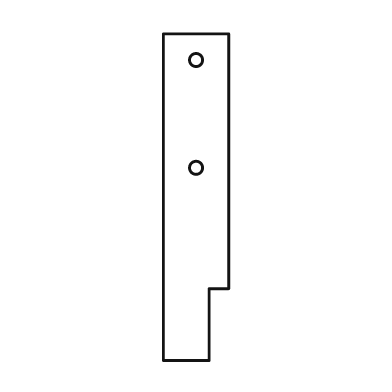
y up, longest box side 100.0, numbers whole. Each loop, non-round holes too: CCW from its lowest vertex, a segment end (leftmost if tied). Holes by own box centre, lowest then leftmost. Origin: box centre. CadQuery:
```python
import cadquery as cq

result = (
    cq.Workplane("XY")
    .moveTo(-10.0, -50.0)
    .lineTo(4.0, -50.0)
    .lineTo(4.0, -28.0)
    .lineTo(10.0, -28.0)
    .lineTo(10.0, 50.0)
    .lineTo(-10.0, 50.0)
    .close()
    .moveTo(0.0, 9.0)
    .circle(2.0)
    .moveTo(0.0, 42.0)
    .circle(2.0)
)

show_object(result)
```